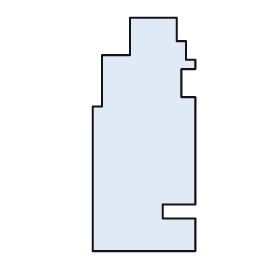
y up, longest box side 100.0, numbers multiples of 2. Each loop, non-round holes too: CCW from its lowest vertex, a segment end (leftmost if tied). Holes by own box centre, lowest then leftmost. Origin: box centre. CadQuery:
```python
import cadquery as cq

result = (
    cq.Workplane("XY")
    .moveTo(-22.0, -50.0)
    .lineTo(22.0, -50.0)
    .lineTo(22.0, -36.0)
    .lineTo(8.0, -36.0)
    .lineTo(8.0, -30.0)
    .lineTo(22.0, -30.0)
    .lineTo(22.0, 16.0)
    .lineTo(16.0, 16.0)
    .lineTo(16.0, 28.0)
    .lineTo(22.0, 28.0)
    .lineTo(22.0, 32.0)
    .lineTo(18.0, 32.0)
    .lineTo(18.0, 40.0)
    .lineTo(14.0, 40.0)
    .lineTo(14.0, 50.0)
    .lineTo(-6.0, 50.0)
    .lineTo(-6.0, 34.0)
    .lineTo(-18.0, 34.0)
    .lineTo(-18.0, 12.0)
    .lineTo(-22.0, 12.0)
    .close()
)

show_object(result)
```